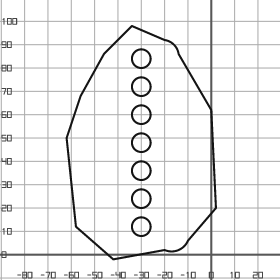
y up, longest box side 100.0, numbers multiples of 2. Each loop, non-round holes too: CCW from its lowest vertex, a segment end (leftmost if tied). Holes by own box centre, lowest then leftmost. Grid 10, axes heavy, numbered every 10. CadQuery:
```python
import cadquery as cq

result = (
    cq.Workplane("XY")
    .moveTo(-42.0, -2.0)
    .lineTo(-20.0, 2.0)
    .threePointArc((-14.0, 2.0), (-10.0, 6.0))
    .lineTo(2.0, 20.0)
    .lineTo(0.0, 62.0)
    .lineTo(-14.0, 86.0)
    .threePointArc((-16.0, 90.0), (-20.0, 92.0))
    .lineTo(-34.0, 98.0)
    .lineTo(-46.0, 86.0)
    .lineTo(-56.0, 68.0)
    .lineTo(-62.0, 50.0)
    .lineTo(-58.0, 12.0)
    .close()
    .moveTo(-30.0, 12.0)
    .circle(4.0)
    .moveTo(-30.0, 24.0)
    .circle(4.0)
    .moveTo(-30.0, 36.0)
    .circle(4.0)
    .moveTo(-30.0, 48.0)
    .circle(4.0)
    .moveTo(-30.0, 60.0)
    .circle(4.0)
    .moveTo(-30.0, 72.0)
    .circle(4.0)
    .moveTo(-30.0, 84.0)
    .circle(4.0)
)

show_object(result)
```